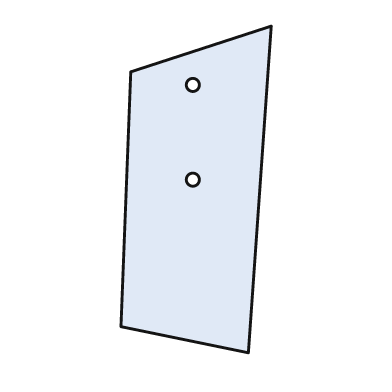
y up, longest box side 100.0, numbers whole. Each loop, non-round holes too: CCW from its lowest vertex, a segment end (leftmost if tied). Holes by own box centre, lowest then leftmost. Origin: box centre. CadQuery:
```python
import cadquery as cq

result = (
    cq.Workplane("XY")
    .moveTo(16.0, -50.0)
    .lineTo(23.0, 50.0)
    .lineTo(-20.0, 36.0)
    .lineTo(-23.0, -42.0)
    .close()
    .moveTo(-1.0, 3.0)
    .circle(2.0)
    .moveTo(-1.0, 32.0)
    .circle(2.0)
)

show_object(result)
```